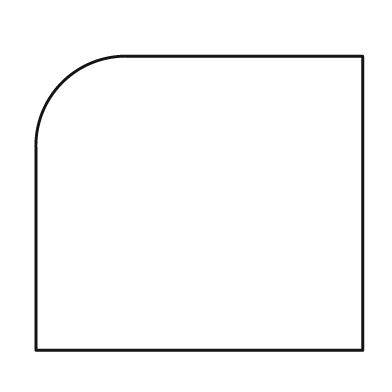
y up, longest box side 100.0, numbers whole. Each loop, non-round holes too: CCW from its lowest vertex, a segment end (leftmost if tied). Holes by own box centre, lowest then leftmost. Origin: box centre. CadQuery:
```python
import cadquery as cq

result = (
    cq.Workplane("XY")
    .moveTo(-50.0, -45.0)
    .lineTo(50.0, -45.0)
    .lineTo(50.0, 45.0)
    .lineTo(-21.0, 45.0)
    .threePointArc((-42.0, 37.0), (-50.0, 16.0))
    .close()
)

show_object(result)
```